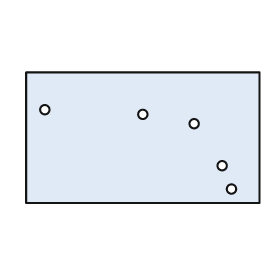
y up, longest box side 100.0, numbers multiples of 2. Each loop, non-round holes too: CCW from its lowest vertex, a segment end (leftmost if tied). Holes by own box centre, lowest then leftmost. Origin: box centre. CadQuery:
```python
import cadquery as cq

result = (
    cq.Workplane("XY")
    .moveTo(-50.0, -28.0)
    .lineTo(50.0, -28.0)
    .lineTo(50.0, 28.0)
    .lineTo(-50.0, 28.0)
    .close()
    .moveTo(38.0, -22.0)
    .circle(2.0)
    .moveTo(34.0, -12.0)
    .circle(2.0)
    .moveTo(22.0, 6.0)
    .circle(2.0)
    .moveTo(0.0, 10.0)
    .circle(2.0)
    .moveTo(-42.0, 12.0)
    .circle(2.0)
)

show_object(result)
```